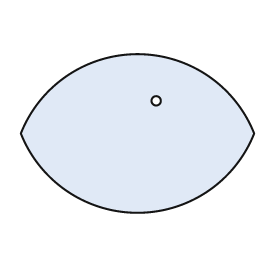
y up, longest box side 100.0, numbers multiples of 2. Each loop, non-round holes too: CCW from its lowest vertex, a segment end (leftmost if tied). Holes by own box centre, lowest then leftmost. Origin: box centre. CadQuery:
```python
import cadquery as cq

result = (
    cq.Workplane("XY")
    .moveTo(-50.0, 0.0)
    .threePointArc((0.0, -34.0), (50.0, 0.0))
    .threePointArc((0.0, 34.0), (-50.0, 0.0))
    .close()
    .moveTo(8.0, 14.0)
    .circle(2.0)
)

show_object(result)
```